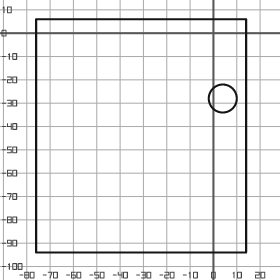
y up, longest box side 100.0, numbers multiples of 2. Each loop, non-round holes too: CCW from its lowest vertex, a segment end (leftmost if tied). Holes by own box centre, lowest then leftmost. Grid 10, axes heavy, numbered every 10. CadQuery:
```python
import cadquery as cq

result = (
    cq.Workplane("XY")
    .moveTo(-76.0, -94.0)
    .lineTo(14.0, -94.0)
    .lineTo(14.0, 6.0)
    .lineTo(-76.0, 6.0)
    .close()
    .moveTo(4.0, -28.0)
    .circle(6.0)
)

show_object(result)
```